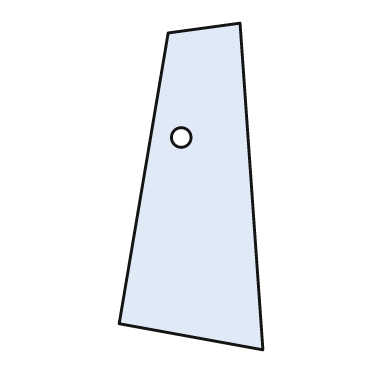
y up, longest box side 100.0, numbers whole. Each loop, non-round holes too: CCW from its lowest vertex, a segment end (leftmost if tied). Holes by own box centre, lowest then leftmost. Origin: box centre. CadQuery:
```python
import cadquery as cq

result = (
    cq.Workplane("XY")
    .moveTo(22.0, -50.0)
    .lineTo(15.0, 50.0)
    .lineTo(-7.0, 47.0)
    .lineTo(-22.0, -42.0)
    .close()
    .moveTo(-3.0, 15.0)
    .circle(3.0)
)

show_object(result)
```